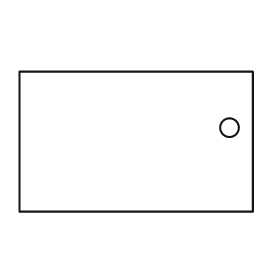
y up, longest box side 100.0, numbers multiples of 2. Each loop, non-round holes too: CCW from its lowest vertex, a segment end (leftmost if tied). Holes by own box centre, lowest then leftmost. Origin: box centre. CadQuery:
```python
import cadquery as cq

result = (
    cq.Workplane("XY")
    .moveTo(-50.0, -30.0)
    .lineTo(50.0, -30.0)
    .lineTo(50.0, 30.0)
    .lineTo(-50.0, 30.0)
    .close()
    .moveTo(40.0, 6.0)
    .circle(4.0)
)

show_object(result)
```